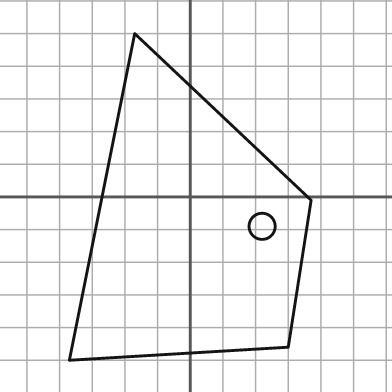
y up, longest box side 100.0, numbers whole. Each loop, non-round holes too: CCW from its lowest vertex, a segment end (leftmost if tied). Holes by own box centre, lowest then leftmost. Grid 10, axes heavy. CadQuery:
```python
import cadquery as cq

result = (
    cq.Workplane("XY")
    .moveTo(-37.0, -50.0)
    .lineTo(30.0, -46.0)
    .lineTo(37.0, -1.0)
    .lineTo(-17.0, 50.0)
    .close()
    .moveTo(22.0, -9.0)
    .circle(4.0)
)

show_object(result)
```